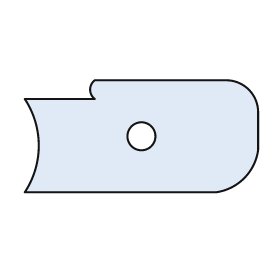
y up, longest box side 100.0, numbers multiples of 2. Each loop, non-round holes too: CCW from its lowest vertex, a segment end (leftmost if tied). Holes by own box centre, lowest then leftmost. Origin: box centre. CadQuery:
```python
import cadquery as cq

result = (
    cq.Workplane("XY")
    .moveTo(-50.0, -24.0)
    .lineTo(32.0, -24.0)
    .threePointArc((44.0, -18.0), (50.0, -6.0))
    .lineTo(50.0, 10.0)
    .threePointArc((46.0, 20.0), (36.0, 24.0))
    .lineTo(-20.0, 24.0)
    .threePointArc((-22.0, 20.0), (-20.0, 16.0))
    .lineTo(-50.0, 16.0)
    .threePointArc((-44.0, -4.0), (-50.0, -24.0))
    .close()
    .moveTo(0.0, 0.0)
    .circle(6.0)
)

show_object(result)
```